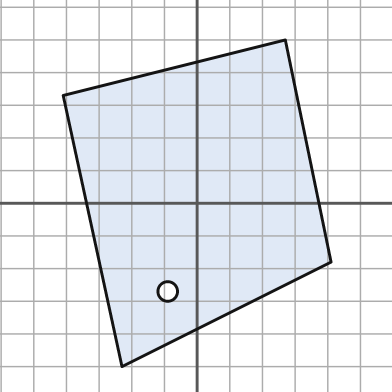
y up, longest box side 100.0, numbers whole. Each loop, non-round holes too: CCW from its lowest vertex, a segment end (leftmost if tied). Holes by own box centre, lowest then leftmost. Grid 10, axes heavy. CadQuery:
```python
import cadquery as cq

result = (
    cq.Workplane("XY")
    .moveTo(-23.0, -50.0)
    .lineTo(41.0, -18.0)
    .lineTo(27.0, 50.0)
    .lineTo(-41.0, 33.0)
    .close()
    .moveTo(-9.0, -27.0)
    .circle(3.0)
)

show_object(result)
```